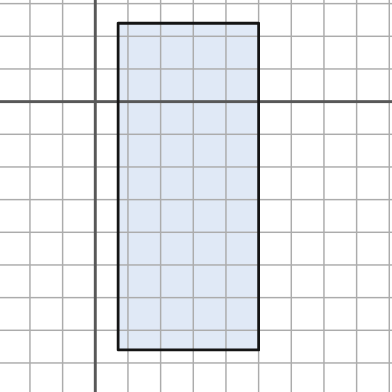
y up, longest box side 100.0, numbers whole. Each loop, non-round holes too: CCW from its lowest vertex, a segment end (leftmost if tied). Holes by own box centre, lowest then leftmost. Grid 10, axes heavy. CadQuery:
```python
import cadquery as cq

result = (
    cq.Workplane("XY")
    .moveTo(7.0, -76.0)
    .lineTo(50.0, -76.0)
    .lineTo(50.0, 24.0)
    .lineTo(7.0, 24.0)
    .close()
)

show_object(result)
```